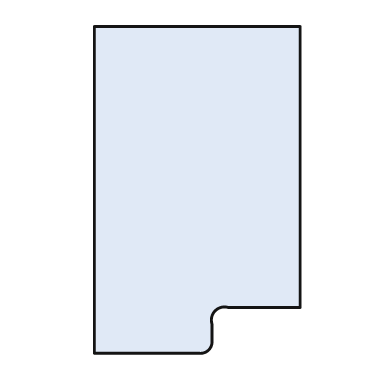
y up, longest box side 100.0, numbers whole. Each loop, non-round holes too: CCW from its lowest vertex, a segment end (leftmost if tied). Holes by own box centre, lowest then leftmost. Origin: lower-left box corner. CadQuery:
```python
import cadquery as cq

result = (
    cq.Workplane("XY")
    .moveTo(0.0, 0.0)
    .lineTo(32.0, 0.0)
    .threePointArc((35.0, 1.0), (36.0, 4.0))
    .lineTo(36.0, 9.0)
    .threePointArc((37.0, 13.0), (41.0, 14.0))
    .lineTo(63.0, 14.0)
    .lineTo(63.0, 100.0)
    .lineTo(0.0, 100.0)
    .close()
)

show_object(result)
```